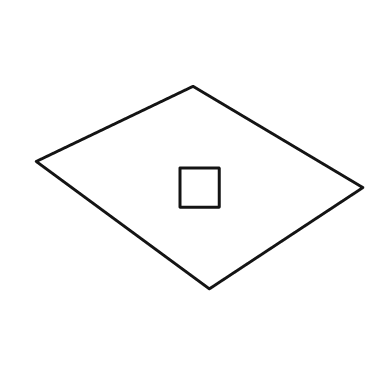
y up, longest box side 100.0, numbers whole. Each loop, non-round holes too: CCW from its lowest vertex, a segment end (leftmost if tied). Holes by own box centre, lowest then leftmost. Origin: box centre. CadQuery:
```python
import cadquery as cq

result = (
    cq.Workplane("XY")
    .moveTo(3.0, -31.0)
    .lineTo(50.0, 0.0)
    .lineTo(-2.0, 31.0)
    .lineTo(-50.0, 8.0)
    .close()
    .moveTo(-6.0, -6.0)
    .lineTo(6.0, -6.0)
    .lineTo(6.0, 6.0)
    .lineTo(-6.0, 6.0)
    .close()
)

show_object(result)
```